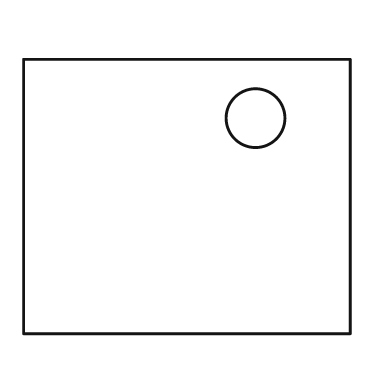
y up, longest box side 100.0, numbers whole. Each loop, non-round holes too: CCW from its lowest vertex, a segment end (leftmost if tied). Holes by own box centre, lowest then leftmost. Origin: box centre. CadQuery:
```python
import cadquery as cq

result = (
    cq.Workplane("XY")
    .moveTo(-50.0, -42.0)
    .lineTo(50.0, -42.0)
    .lineTo(50.0, 42.0)
    .lineTo(-50.0, 42.0)
    .close()
    .moveTo(21.0, 24.0)
    .circle(9.0)
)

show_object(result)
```